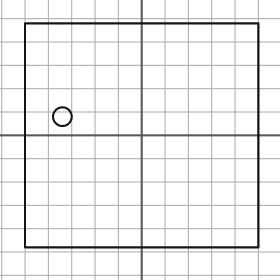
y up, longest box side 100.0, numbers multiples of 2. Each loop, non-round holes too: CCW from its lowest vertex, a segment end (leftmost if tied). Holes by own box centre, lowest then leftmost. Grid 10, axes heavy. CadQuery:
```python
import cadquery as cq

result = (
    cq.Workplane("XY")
    .moveTo(-50.0, -48.0)
    .lineTo(50.0, -48.0)
    .lineTo(50.0, 48.0)
    .lineTo(-50.0, 48.0)
    .close()
    .moveTo(-34.0, 8.0)
    .circle(4.0)
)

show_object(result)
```